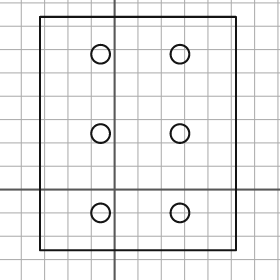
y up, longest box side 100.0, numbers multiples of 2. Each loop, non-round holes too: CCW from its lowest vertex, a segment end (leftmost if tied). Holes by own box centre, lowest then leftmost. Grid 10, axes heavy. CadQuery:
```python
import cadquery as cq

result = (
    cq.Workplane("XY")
    .moveTo(-32.0, -26.0)
    .lineTo(52.0, -26.0)
    .lineTo(52.0, 74.0)
    .lineTo(-32.0, 74.0)
    .close()
    .moveTo(-6.0, -10.0)
    .circle(4.0)
    .moveTo(28.0, -10.0)
    .circle(4.0)
    .moveTo(-6.0, 24.0)
    .circle(4.0)
    .moveTo(28.0, 24.0)
    .circle(4.0)
    .moveTo(-6.0, 58.0)
    .circle(4.0)
    .moveTo(28.0, 58.0)
    .circle(4.0)
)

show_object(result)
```